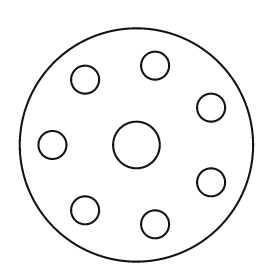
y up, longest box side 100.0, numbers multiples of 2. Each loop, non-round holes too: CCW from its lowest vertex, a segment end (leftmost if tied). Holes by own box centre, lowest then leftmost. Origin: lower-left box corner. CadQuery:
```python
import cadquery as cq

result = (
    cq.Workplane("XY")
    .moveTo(50.0, 50.0)
    .circle(50.0)
    .moveTo(58.0, 16.0)
    .circle(6.0)
    .moveTo(28.0, 22.0)
    .circle(6.0)
    .moveTo(82.0, 34.0)
    .circle(6.0)
    .moveTo(14.0, 50.0)
    .circle(6.0)
    .moveTo(50.0, 50.0)
    .circle(10.0)
    .moveTo(82.0, 66.0)
    .circle(6.0)
    .moveTo(28.0, 78.0)
    .circle(6.0)
    .moveTo(58.0, 84.0)
    .circle(6.0)
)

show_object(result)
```